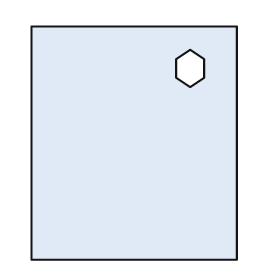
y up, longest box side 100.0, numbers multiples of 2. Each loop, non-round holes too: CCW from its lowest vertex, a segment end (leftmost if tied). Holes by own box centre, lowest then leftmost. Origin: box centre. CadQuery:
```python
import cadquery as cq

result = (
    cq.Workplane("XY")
    .moveTo(-44.0, -50.0)
    .lineTo(44.0, -50.0)
    .lineTo(44.0, 50.0)
    .lineTo(-44.0, 50.0)
    .close()
    .moveTo(24.0, 24.0)
    .lineTo(30.0, 28.0)
    .lineTo(30.0, 36.0)
    .lineTo(24.0, 40.0)
    .lineTo(18.0, 36.0)
    .lineTo(18.0, 28.0)
    .close()
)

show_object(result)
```